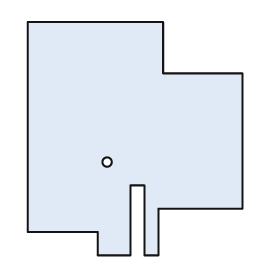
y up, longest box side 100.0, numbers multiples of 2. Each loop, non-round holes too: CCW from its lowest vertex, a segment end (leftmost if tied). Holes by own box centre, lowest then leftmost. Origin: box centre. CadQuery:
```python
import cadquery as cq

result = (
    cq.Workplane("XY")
    .moveTo(-16.0, -50.0)
    .lineTo(-2.0, -50.0)
    .lineTo(-2.0, -20.0)
    .lineTo(4.0, -20.0)
    .lineTo(4.0, -50.0)
    .lineTo(10.0, -50.0)
    .lineTo(10.0, -30.0)
    .lineTo(46.0, -30.0)
    .lineTo(46.0, 28.0)
    .lineTo(12.0, 28.0)
    .lineTo(12.0, 50.0)
    .lineTo(-46.0, 50.0)
    .lineTo(-46.0, -40.0)
    .lineTo(-16.0, -40.0)
    .close()
    .moveTo(-12.0, -10.0)
    .circle(2.0)
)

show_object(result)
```